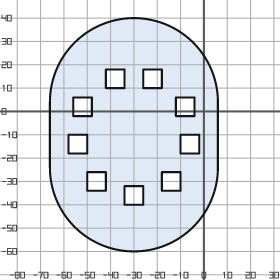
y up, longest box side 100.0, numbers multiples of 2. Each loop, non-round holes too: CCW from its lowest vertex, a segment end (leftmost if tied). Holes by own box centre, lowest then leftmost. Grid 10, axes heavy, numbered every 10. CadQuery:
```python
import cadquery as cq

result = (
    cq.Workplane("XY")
    .moveTo(-66.0, -24.0)
    .threePointArc((-30.0, -60.0), (6.0, -24.0))
    .lineTo(6.0, 4.0)
    .threePointArc((-30.0, 40.0), (-66.0, 4.0))
    .close()
    .moveTo(-34.0, -40.0)
    .lineTo(-26.0, -40.0)
    .lineTo(-26.0, -32.0)
    .lineTo(-34.0, -32.0)
    .close()
    .moveTo(-50.0, -34.0)
    .lineTo(-42.0, -34.0)
    .lineTo(-42.0, -26.0)
    .lineTo(-50.0, -26.0)
    .close()
    .moveTo(-18.0, -34.0)
    .lineTo(-10.0, -34.0)
    .lineTo(-10.0, -26.0)
    .lineTo(-18.0, -26.0)
    .close()
    .moveTo(-58.0, -18.0)
    .lineTo(-50.0, -18.0)
    .lineTo(-50.0, -10.0)
    .lineTo(-58.0, -10.0)
    .close()
    .moveTo(-10.0, -18.0)
    .lineTo(-2.0, -18.0)
    .lineTo(-2.0, -10.0)
    .lineTo(-10.0, -10.0)
    .close()
    .moveTo(-56.0, -2.0)
    .lineTo(-48.0, -2.0)
    .lineTo(-48.0, 6.0)
    .lineTo(-56.0, 6.0)
    .close()
    .moveTo(-12.0, -2.0)
    .lineTo(-4.0, -2.0)
    .lineTo(-4.0, 6.0)
    .lineTo(-12.0, 6.0)
    .close()
    .moveTo(-42.0, 10.0)
    .lineTo(-34.0, 10.0)
    .lineTo(-34.0, 18.0)
    .lineTo(-42.0, 18.0)
    .close()
    .moveTo(-26.0, 10.0)
    .lineTo(-18.0, 10.0)
    .lineTo(-18.0, 18.0)
    .lineTo(-26.0, 18.0)
    .close()
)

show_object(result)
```